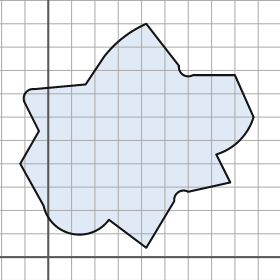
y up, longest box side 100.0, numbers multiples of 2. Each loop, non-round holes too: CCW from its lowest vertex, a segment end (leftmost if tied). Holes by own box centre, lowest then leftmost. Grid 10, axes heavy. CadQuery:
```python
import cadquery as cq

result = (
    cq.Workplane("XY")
    .moveTo(42.0, 4.0)
    .lineTo(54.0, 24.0)
    .threePointArc((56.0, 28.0), (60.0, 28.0))
    .lineTo(78.0, 32.0)
    .lineTo(72.0, 44.0)
    .threePointArc((82.0, 50.0), (88.0, 60.0))
    .lineTo(80.0, 78.0)
    .lineTo(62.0, 78.0)
    .threePointArc((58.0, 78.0), (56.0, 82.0))
    .lineTo(42.0, 100.0)
    .threePointArc((32.0, 94.0), (24.0, 86.0))
    .lineTo(16.0, 74.0)
    .lineTo(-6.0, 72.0)
    .threePointArc((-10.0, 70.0), (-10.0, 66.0))
    .lineTo(-4.0, 54.0)
    .lineTo(-12.0, 40.0)
    .lineTo(-2.0, 22.0)
    .threePointArc((10.0, 10.0), (26.0, 16.0))
    .close()
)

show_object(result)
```